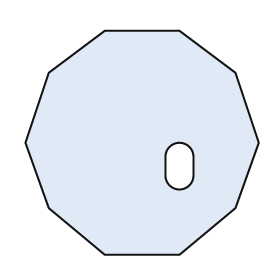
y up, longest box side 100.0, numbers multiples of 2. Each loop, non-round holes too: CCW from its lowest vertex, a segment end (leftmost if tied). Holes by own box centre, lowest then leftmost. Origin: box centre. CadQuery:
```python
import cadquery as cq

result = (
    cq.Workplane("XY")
    .moveTo(-16.0, -48.0)
    .lineTo(16.0, -48.0)
    .lineTo(40.0, -28.0)
    .lineTo(50.0, 0.0)
    .lineTo(40.0, 30.0)
    .lineTo(16.0, 48.0)
    .lineTo(-16.0, 48.0)
    .lineTo(-40.0, 30.0)
    .lineTo(-50.0, 0.0)
    .lineTo(-40.0, -28.0)
    .close()
    .moveTo(10.0, -14.0)
    .threePointArc((16.0, -20.0), (22.0, -14.0))
    .lineTo(22.0, -6.0)
    .threePointArc((16.0, 0.0), (10.0, -6.0))
    .close()
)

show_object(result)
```